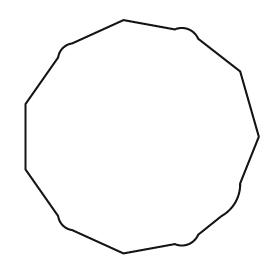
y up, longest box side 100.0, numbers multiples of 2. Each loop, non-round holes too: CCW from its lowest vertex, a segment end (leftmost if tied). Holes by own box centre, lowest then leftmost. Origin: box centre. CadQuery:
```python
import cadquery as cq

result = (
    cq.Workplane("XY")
    .moveTo(-8.0, -50.0)
    .lineTo(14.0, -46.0)
    .threePointArc((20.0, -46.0), (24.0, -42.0))
    .lineTo(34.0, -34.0)
    .threePointArc((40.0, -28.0), (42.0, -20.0))
    .lineTo(50.0, 0.0)
    .lineTo(42.0, 28.0)
    .lineTo(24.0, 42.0)
    .threePointArc((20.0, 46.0), (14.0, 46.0))
    .lineTo(-8.0, 50.0)
    .lineTo(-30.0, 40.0)
    .threePointArc((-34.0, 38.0), (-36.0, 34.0))
    .lineTo(-50.0, 14.0)
    .lineTo(-50.0, -14.0)
    .lineTo(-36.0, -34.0)
    .threePointArc((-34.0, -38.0), (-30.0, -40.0))
    .close()
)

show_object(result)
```